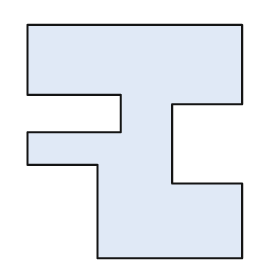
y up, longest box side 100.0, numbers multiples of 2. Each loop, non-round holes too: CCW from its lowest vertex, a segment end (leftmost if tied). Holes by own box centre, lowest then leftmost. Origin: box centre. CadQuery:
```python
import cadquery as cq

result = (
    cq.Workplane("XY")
    .moveTo(-16.0, -50.0)
    .lineTo(46.0, -50.0)
    .lineTo(46.0, -18.0)
    .lineTo(16.0, -18.0)
    .lineTo(16.0, 16.0)
    .lineTo(46.0, 16.0)
    .lineTo(46.0, 50.0)
    .lineTo(-46.0, 50.0)
    .lineTo(-46.0, 20.0)
    .lineTo(-6.0, 20.0)
    .lineTo(-6.0, 4.0)
    .lineTo(-46.0, 4.0)
    .lineTo(-46.0, -10.0)
    .lineTo(-16.0, -10.0)
    .close()
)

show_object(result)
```